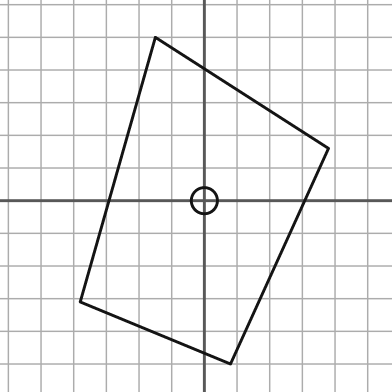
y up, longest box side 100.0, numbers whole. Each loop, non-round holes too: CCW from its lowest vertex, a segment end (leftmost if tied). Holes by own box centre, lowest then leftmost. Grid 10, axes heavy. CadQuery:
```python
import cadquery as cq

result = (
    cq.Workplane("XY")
    .moveTo(8.0, -50.0)
    .lineTo(38.0, 16.0)
    .lineTo(-15.0, 50.0)
    .lineTo(-38.0, -31.0)
    .close()
    .moveTo(0.0, 0.0)
    .circle(4.0)
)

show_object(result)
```